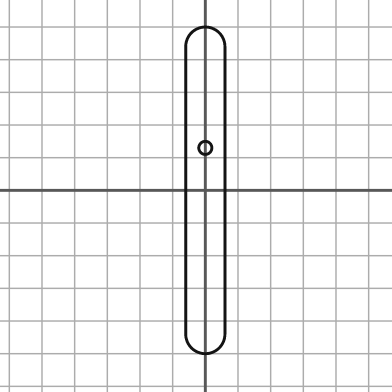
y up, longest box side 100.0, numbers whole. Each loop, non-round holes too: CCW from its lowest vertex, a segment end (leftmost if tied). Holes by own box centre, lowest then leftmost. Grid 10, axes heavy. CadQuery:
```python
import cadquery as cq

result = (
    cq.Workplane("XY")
    .moveTo(-6.0, -44.0)
    .threePointArc((0.0, -50.0), (6.0, -44.0))
    .lineTo(6.0, 44.0)
    .threePointArc((0.0, 50.0), (-6.0, 44.0))
    .close()
    .moveTo(0.0, 13.0)
    .circle(2.0)
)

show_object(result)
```